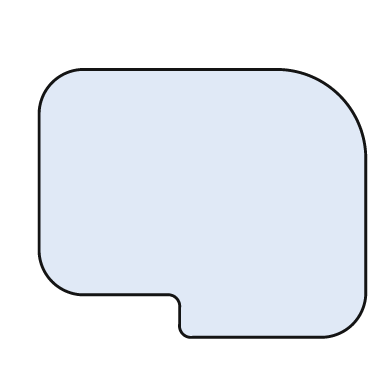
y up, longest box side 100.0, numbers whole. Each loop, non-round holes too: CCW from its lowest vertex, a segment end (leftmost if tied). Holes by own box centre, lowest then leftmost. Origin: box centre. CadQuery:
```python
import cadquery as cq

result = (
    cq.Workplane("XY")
    .moveTo(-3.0, -41.0)
    .lineTo(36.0, -41.0)
    .threePointArc((46.0, -37.0), (50.0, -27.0))
    .lineTo(50.0, 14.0)
    .threePointArc((42.0, 33.0), (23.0, 41.0))
    .lineTo(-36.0, 41.0)
    .threePointArc((-46.0, 37.0), (-50.0, 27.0))
    .lineTo(-50.0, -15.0)
    .threePointArc((-46.0, -24.0), (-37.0, -28.0))
    .lineTo(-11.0, -28.0)
    .threePointArc((-8.0, -29.0), (-7.0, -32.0))
    .lineTo(-7.0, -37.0)
    .threePointArc((-6.0, -40.0), (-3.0, -41.0))
    .close()
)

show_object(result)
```